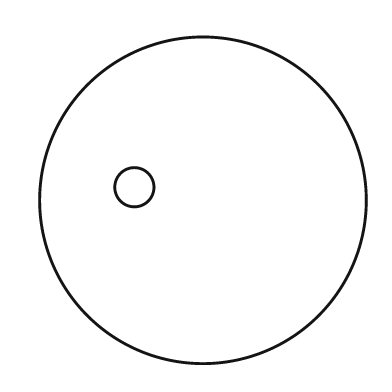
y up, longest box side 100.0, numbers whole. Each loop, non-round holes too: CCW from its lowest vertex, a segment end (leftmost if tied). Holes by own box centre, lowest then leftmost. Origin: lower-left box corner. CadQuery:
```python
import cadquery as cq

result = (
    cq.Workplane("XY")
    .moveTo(50.0, 50.0)
    .circle(50.0)
    .moveTo(29.0, 54.0)
    .circle(6.0)
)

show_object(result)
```